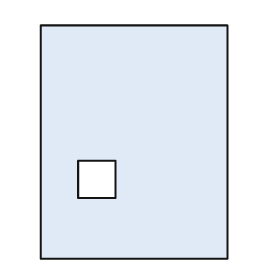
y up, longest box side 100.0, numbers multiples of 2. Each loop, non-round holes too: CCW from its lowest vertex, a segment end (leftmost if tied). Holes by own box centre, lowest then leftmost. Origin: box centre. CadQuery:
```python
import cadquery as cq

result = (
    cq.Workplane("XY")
    .moveTo(-40.0, -50.0)
    .lineTo(40.0, -50.0)
    .lineTo(40.0, 50.0)
    .lineTo(-40.0, 50.0)
    .close()
    .moveTo(-24.0, -24.0)
    .lineTo(-8.0, -24.0)
    .lineTo(-8.0, -8.0)
    .lineTo(-24.0, -8.0)
    .close()
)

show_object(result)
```